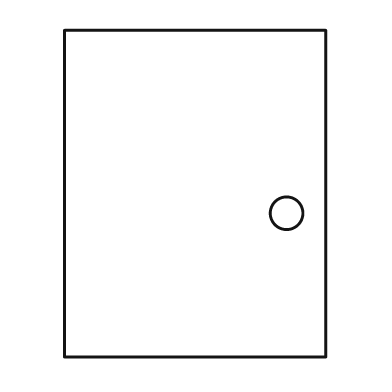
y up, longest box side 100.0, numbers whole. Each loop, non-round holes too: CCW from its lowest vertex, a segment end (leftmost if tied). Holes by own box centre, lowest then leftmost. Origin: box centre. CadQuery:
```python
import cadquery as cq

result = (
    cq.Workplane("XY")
    .moveTo(-40.0, -50.0)
    .lineTo(40.0, -50.0)
    .lineTo(40.0, 50.0)
    .lineTo(-40.0, 50.0)
    .close()
    .moveTo(28.0, -6.0)
    .circle(5.0)
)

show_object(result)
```